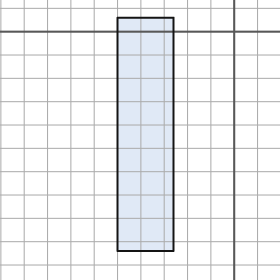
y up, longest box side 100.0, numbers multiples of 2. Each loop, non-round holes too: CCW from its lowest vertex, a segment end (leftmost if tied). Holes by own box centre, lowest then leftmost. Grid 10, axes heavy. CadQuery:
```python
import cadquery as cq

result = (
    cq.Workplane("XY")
    .moveTo(-50.0, -94.0)
    .lineTo(-26.0, -94.0)
    .lineTo(-26.0, 6.0)
    .lineTo(-50.0, 6.0)
    .close()
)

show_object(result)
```